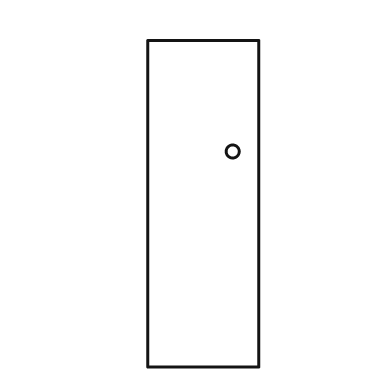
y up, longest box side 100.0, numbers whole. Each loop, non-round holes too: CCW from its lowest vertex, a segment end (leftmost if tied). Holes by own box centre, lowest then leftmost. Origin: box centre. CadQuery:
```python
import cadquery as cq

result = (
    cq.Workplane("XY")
    .moveTo(-17.0, -50.0)
    .lineTo(17.0, -50.0)
    .lineTo(17.0, 50.0)
    .lineTo(-17.0, 50.0)
    .close()
    .moveTo(9.0, 16.0)
    .circle(2.0)
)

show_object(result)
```